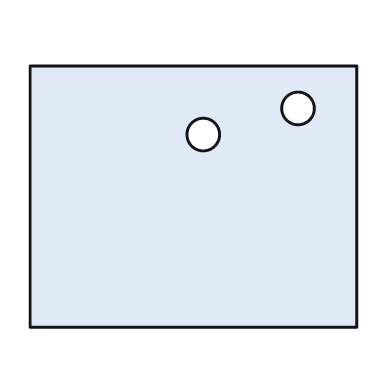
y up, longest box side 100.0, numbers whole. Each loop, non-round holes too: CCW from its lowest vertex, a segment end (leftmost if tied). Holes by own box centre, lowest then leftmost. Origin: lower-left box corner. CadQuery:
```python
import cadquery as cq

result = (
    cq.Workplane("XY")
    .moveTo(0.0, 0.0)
    .lineTo(100.0, 0.0)
    .lineTo(100.0, 80.0)
    .lineTo(0.0, 80.0)
    .close()
    .moveTo(53.0, 59.0)
    .circle(5.0)
    .moveTo(82.0, 67.0)
    .circle(5.0)
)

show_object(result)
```